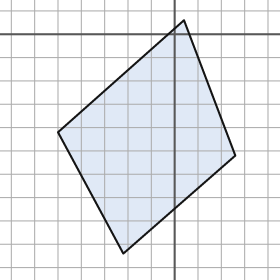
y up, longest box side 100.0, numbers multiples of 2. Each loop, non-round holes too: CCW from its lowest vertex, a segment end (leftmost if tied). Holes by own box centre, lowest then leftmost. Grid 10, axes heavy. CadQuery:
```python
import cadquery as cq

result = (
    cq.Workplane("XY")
    .moveTo(-22.0, -94.0)
    .lineTo(26.0, -52.0)
    .lineTo(4.0, 6.0)
    .lineTo(-50.0, -42.0)
    .close()
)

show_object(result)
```